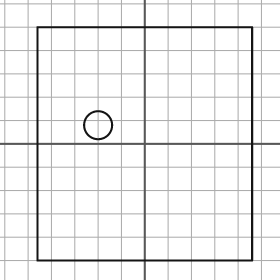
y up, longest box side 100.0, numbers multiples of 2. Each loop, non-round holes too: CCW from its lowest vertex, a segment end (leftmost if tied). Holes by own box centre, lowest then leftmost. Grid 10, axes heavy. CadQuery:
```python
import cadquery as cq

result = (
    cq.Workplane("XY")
    .moveTo(-46.0, -50.0)
    .lineTo(46.0, -50.0)
    .lineTo(46.0, 50.0)
    .lineTo(-46.0, 50.0)
    .close()
    .moveTo(-20.0, 8.0)
    .circle(6.0)
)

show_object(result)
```